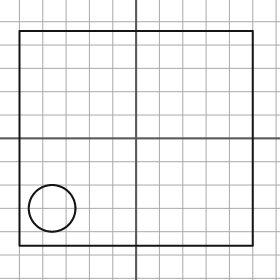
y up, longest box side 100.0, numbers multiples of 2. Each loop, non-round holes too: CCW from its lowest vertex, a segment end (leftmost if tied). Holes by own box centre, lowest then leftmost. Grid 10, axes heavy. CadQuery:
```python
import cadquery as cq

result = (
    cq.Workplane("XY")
    .moveTo(-50.0, -46.0)
    .lineTo(50.0, -46.0)
    .lineTo(50.0, 46.0)
    .lineTo(-50.0, 46.0)
    .close()
    .moveTo(-36.0, -30.0)
    .circle(10.0)
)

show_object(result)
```